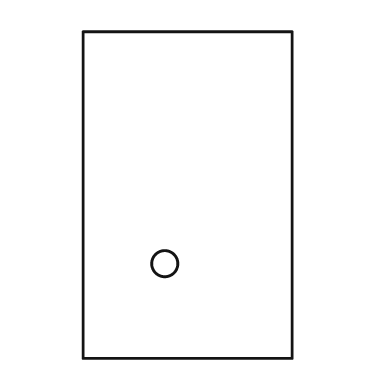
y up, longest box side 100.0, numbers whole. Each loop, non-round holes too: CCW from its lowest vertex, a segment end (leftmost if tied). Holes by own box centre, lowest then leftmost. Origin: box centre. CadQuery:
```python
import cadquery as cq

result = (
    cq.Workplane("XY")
    .moveTo(-32.0, -50.0)
    .lineTo(32.0, -50.0)
    .lineTo(32.0, 50.0)
    .lineTo(-32.0, 50.0)
    .close()
    .moveTo(-7.0, -21.0)
    .circle(4.0)
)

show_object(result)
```